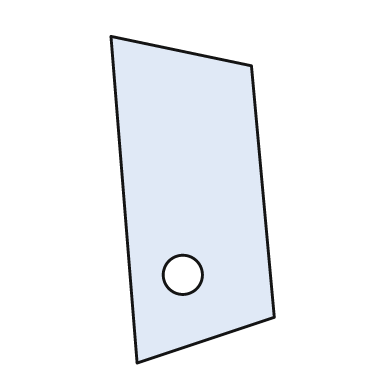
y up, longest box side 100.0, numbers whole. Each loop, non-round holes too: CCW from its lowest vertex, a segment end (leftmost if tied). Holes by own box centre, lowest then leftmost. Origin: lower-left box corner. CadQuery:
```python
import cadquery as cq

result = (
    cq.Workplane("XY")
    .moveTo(8.0, 0.0)
    .lineTo(50.0, 14.0)
    .lineTo(43.0, 91.0)
    .lineTo(0.0, 100.0)
    .close()
    .moveTo(22.0, 27.0)
    .circle(6.0)
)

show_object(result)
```